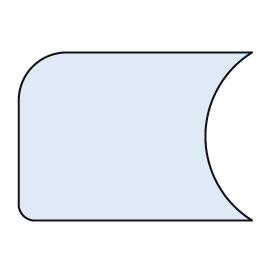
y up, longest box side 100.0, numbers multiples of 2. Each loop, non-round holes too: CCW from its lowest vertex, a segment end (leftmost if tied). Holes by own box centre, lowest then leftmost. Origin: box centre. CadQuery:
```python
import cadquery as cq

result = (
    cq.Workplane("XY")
    .moveTo(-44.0, -36.0)
    .lineTo(50.0, -36.0)
    .threePointArc((30.0, 0.0), (50.0, 36.0))
    .lineTo(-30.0, 36.0)
    .threePointArc((-44.0, 30.0), (-50.0, 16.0))
    .lineTo(-50.0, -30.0)
    .threePointArc((-48.0, -34.0), (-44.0, -36.0))
    .close()
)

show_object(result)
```